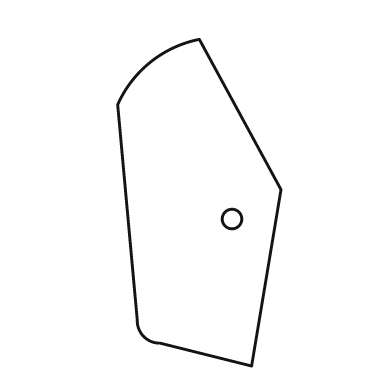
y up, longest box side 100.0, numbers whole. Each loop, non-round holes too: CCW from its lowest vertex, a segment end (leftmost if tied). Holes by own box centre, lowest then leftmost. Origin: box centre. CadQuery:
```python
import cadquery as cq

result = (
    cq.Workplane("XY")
    .moveTo(16.0, -50.0)
    .lineTo(25.0, 4.0)
    .lineTo(0.0, 50.0)
    .threePointArc((-15.0, 43.0), (-25.0, 30.0))
    .lineTo(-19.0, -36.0)
    .threePointArc((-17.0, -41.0), (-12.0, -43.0))
    .close()
    .moveTo(10.0, -5.0)
    .circle(3.0)
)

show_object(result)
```